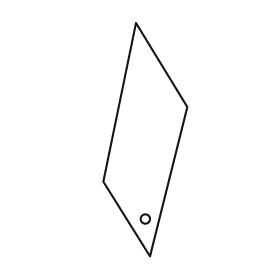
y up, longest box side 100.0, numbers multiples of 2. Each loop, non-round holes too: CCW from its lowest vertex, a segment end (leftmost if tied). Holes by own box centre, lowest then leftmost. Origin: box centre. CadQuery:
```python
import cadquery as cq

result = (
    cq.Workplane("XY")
    .moveTo(2.0, -50.0)
    .lineTo(18.0, 14.0)
    .lineTo(-4.0, 50.0)
    .lineTo(-18.0, -18.0)
    .close()
    .moveTo(0.0, -34.0)
    .circle(2.0)
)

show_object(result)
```